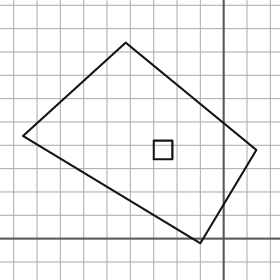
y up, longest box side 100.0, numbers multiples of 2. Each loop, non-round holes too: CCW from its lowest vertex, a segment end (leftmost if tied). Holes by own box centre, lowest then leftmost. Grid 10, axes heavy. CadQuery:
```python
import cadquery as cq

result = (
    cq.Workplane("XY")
    .moveTo(-10.0, -2.0)
    .lineTo(14.0, 38.0)
    .lineTo(-42.0, 84.0)
    .lineTo(-86.0, 44.0)
    .close()
    .moveTo(-30.0, 34.0)
    .lineTo(-22.0, 34.0)
    .lineTo(-22.0, 42.0)
    .lineTo(-30.0, 42.0)
    .close()
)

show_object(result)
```